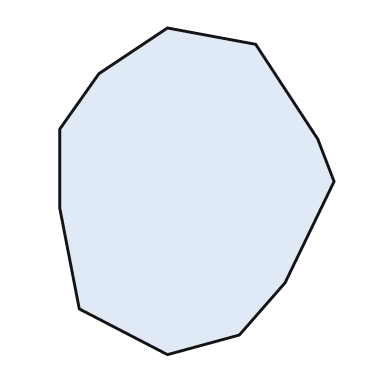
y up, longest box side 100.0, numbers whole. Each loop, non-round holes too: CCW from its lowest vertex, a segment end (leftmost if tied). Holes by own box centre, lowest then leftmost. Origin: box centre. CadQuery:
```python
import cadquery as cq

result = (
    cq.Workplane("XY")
    .moveTo(-9.0, -50.0)
    .lineTo(13.0, -44.0)
    .lineTo(27.0, -28.0)
    .lineTo(42.0, 3.0)
    .lineTo(37.0, 16.0)
    .lineTo(18.0, 45.0)
    .lineTo(-9.0, 50.0)
    .lineTo(-30.0, 36.0)
    .lineTo(-42.0, 19.0)
    .lineTo(-42.0, -5.0)
    .lineTo(-36.0, -36.0)
    .close()
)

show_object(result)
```